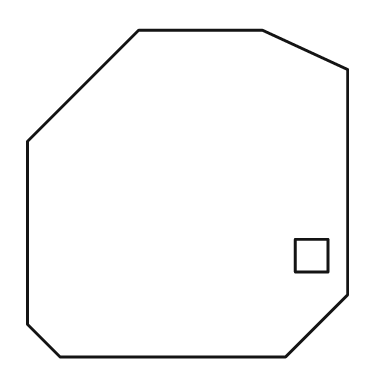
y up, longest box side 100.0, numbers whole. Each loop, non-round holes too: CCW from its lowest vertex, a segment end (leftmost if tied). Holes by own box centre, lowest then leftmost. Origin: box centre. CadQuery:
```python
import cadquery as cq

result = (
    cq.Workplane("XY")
    .moveTo(-39.0, -50.0)
    .lineTo(30.0, -50.0)
    .lineTo(49.0, -31.0)
    .lineTo(49.0, 38.0)
    .lineTo(23.0, 50.0)
    .lineTo(-15.0, 50.0)
    .lineTo(-49.0, 16.0)
    .lineTo(-49.0, -40.0)
    .close()
    .moveTo(33.0, -24.0)
    .lineTo(43.0, -24.0)
    .lineTo(43.0, -14.0)
    .lineTo(33.0, -14.0)
    .close()
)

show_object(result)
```